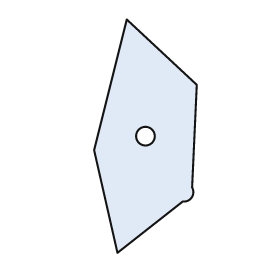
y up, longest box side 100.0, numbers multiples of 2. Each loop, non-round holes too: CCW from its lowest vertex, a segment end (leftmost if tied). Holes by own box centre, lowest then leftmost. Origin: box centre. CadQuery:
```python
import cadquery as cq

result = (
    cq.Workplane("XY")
    .moveTo(-12.0, -50.0)
    .lineTo(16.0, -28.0)
    .threePointArc((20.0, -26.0), (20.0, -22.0))
    .lineTo(22.0, 22.0)
    .lineTo(-8.0, 50.0)
    .lineTo(-22.0, -6.0)
    .close()
    .moveTo(0.0, 0.0)
    .circle(4.0)
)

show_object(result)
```